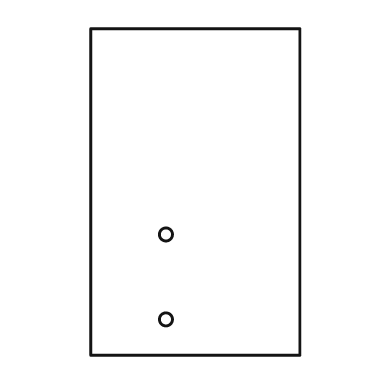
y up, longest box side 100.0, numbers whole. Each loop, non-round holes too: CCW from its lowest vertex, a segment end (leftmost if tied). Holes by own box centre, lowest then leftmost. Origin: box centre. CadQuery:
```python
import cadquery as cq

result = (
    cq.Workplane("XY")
    .moveTo(-32.0, -50.0)
    .lineTo(32.0, -50.0)
    .lineTo(32.0, 50.0)
    .lineTo(-32.0, 50.0)
    .close()
    .moveTo(-9.0, -39.0)
    .circle(2.0)
    .moveTo(-9.0, -13.0)
    .circle(2.0)
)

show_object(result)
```